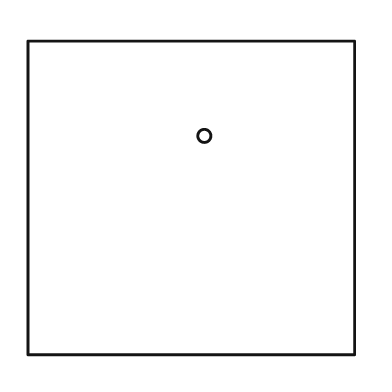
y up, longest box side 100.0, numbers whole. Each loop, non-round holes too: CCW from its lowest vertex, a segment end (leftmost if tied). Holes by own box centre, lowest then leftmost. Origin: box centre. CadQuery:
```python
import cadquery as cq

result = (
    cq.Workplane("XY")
    .moveTo(-50.0, -48.0)
    .lineTo(50.0, -48.0)
    .lineTo(50.0, 48.0)
    .lineTo(-50.0, 48.0)
    .close()
    .moveTo(4.0, 19.0)
    .circle(2.0)
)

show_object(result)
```